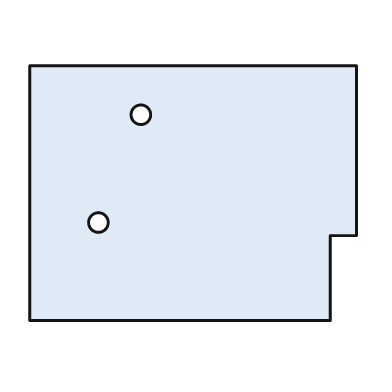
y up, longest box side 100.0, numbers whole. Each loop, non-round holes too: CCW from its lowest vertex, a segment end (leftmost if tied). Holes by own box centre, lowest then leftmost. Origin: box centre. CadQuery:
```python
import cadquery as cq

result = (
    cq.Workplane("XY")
    .moveTo(-50.0, -39.0)
    .lineTo(42.0, -39.0)
    .lineTo(42.0, -13.0)
    .lineTo(50.0, -13.0)
    .lineTo(50.0, 39.0)
    .lineTo(-50.0, 39.0)
    .close()
    .moveTo(-29.0, -9.0)
    .circle(3.0)
    .moveTo(-16.0, 24.0)
    .circle(3.0)
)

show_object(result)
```